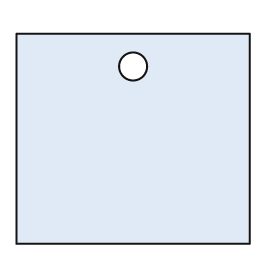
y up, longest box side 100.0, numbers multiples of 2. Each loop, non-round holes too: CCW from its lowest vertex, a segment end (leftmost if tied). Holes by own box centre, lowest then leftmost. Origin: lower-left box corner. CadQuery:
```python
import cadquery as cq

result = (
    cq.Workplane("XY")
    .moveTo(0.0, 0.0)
    .lineTo(100.0, 0.0)
    .lineTo(100.0, 90.0)
    .lineTo(0.0, 90.0)
    .close()
    .moveTo(50.0, 76.0)
    .circle(6.0)
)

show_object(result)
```